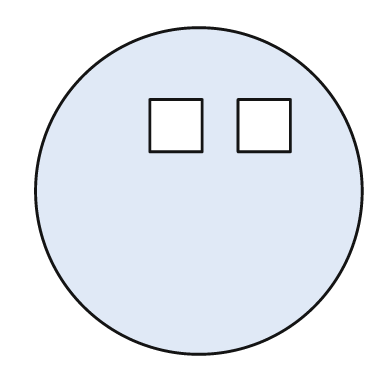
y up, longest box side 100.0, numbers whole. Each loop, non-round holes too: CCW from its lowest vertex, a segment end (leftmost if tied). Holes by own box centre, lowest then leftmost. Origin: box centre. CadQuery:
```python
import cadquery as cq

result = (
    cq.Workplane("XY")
    .moveTo(0.0, 0.0)
    .circle(50.0)
    .moveTo(-15.0, 12.0)
    .lineTo(1.0, 12.0)
    .lineTo(1.0, 28.0)
    .lineTo(-15.0, 28.0)
    .close()
    .moveTo(12.0, 12.0)
    .lineTo(28.0, 12.0)
    .lineTo(28.0, 28.0)
    .lineTo(12.0, 28.0)
    .close()
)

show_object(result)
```